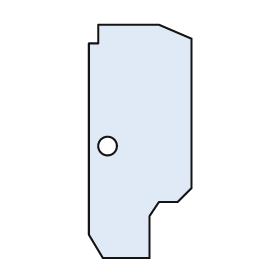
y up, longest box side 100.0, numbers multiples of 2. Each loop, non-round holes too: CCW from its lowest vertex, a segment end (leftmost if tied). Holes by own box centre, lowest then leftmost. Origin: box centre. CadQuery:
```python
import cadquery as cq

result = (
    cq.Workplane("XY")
    .moveTo(-16.0, -50.0)
    .lineTo(4.0, -50.0)
    .lineTo(4.0, -32.0)
    .lineTo(8.0, -26.0)
    .lineTo(16.0, -26.0)
    .lineTo(22.0, -20.0)
    .lineTo(22.0, 44.0)
    .lineTo(8.0, 50.0)
    .lineTo(-18.0, 50.0)
    .lineTo(-18.0, 42.0)
    .lineTo(-22.0, 42.0)
    .lineTo(-22.0, -40.0)
    .close()
    .moveTo(-14.0, -2.0)
    .circle(4.0)
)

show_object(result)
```